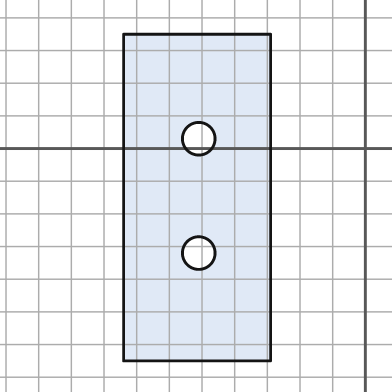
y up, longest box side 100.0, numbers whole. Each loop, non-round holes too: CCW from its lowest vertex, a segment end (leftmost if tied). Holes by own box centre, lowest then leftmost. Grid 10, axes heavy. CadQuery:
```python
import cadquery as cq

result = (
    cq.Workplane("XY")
    .moveTo(-74.0, -65.0)
    .lineTo(-29.0, -65.0)
    .lineTo(-29.0, 35.0)
    .lineTo(-74.0, 35.0)
    .close()
    .moveTo(-51.0, -32.0)
    .circle(5.0)
    .moveTo(-51.0, 3.0)
    .circle(5.0)
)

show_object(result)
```